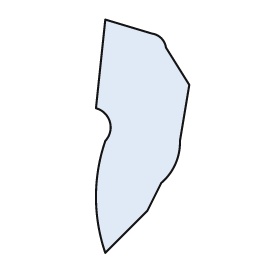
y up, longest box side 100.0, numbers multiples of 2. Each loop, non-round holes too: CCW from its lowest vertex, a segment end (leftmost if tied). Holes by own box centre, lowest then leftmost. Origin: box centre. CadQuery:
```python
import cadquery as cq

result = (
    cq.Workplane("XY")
    .moveTo(-16.0, -50.0)
    .lineTo(2.0, -32.0)
    .lineTo(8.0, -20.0)
    .threePointArc((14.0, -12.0), (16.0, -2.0))
    .lineTo(20.0, 22.0)
    .lineTo(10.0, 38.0)
    .threePointArc((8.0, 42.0), (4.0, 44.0))
    .lineTo(-16.0, 50.0)
    .lineTo(-20.0, 12.0)
    .threePointArc((-14.0, 6.0), (-16.0, -2.0))
    .threePointArc((-20.0, -26.0), (-16.0, -50.0))
    .close()
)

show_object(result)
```